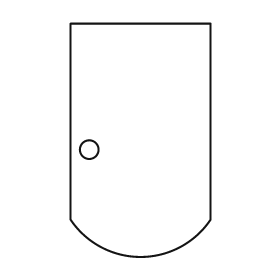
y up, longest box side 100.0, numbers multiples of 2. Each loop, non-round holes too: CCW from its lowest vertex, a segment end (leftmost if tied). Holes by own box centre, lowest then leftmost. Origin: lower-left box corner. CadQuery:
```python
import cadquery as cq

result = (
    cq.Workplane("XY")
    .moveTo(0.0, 16.0)
    .threePointArc((30.0, 0.0), (60.0, 16.0))
    .lineTo(60.0, 100.0)
    .lineTo(0.0, 100.0)
    .close()
    .moveTo(8.0, 46.0)
    .circle(4.0)
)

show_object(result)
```